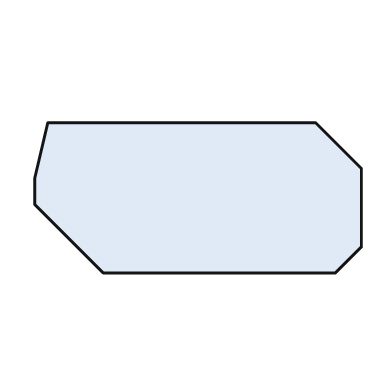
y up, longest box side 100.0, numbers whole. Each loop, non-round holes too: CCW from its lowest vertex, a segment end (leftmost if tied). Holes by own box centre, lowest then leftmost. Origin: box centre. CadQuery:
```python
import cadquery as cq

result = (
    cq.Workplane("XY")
    .moveTo(-29.0, -23.0)
    .lineTo(42.0, -23.0)
    .lineTo(50.0, -15.0)
    .lineTo(50.0, 9.0)
    .lineTo(36.0, 23.0)
    .lineTo(-46.0, 23.0)
    .lineTo(-50.0, 6.0)
    .lineTo(-50.0, -2.0)
    .close()
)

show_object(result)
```